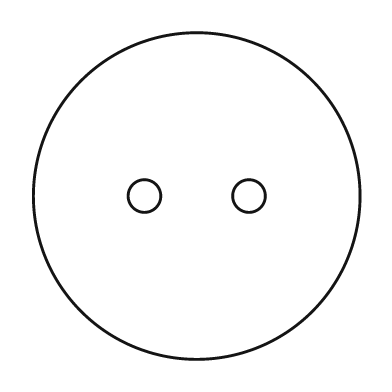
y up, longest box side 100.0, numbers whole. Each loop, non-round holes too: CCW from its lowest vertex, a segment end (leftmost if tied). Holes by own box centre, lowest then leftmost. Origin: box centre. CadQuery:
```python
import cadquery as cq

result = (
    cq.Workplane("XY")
    .moveTo(0.0, 0.0)
    .circle(50.0)
    .moveTo(-16.0, 0.0)
    .circle(5.0)
    .moveTo(16.0, 0.0)
    .circle(5.0)
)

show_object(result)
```